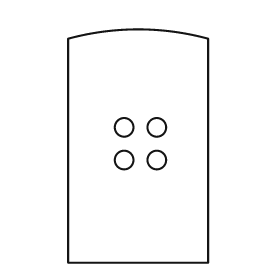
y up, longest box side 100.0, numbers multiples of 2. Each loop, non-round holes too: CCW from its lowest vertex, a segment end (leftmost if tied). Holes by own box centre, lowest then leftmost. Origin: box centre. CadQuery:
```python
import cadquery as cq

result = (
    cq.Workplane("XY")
    .moveTo(-30.0, -50.0)
    .lineTo(30.0, -50.0)
    .lineTo(30.0, 46.0)
    .threePointArc((0.0, 50.0), (-30.0, 46.0))
    .close()
    .moveTo(-6.0, -6.0)
    .circle(4.0)
    .moveTo(8.0, -6.0)
    .circle(4.0)
    .moveTo(-6.0, 8.0)
    .circle(4.0)
    .moveTo(8.0, 8.0)
    .circle(4.0)
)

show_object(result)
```